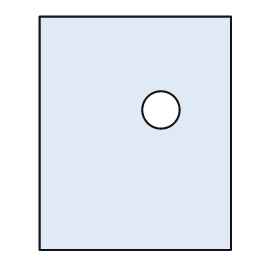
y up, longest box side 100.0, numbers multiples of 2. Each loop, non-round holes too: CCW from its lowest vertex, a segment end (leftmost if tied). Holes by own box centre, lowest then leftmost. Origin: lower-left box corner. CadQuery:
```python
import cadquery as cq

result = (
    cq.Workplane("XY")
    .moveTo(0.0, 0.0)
    .lineTo(82.0, 0.0)
    .lineTo(82.0, 100.0)
    .lineTo(0.0, 100.0)
    .close()
    .moveTo(52.0, 60.0)
    .circle(8.0)
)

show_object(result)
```